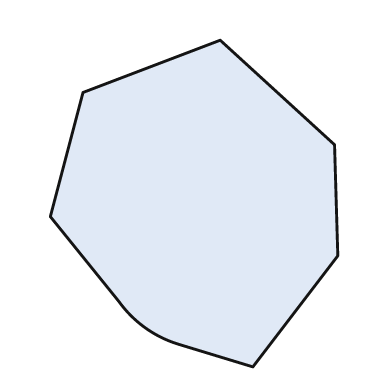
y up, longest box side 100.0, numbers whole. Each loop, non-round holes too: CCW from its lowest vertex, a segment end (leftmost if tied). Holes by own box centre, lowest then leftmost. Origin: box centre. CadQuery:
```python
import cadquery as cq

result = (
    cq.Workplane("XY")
    .moveTo(18.0, -50.0)
    .lineTo(44.0, -16.0)
    .lineTo(43.0, 18.0)
    .lineTo(8.0, 50.0)
    .lineTo(-34.0, 34.0)
    .lineTo(-44.0, -4.0)
    .lineTo(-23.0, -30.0)
    .threePointArc((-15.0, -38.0), (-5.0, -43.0))
    .close()
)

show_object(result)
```